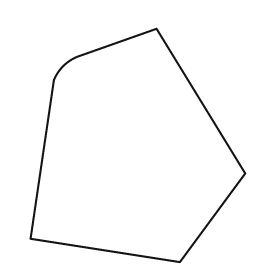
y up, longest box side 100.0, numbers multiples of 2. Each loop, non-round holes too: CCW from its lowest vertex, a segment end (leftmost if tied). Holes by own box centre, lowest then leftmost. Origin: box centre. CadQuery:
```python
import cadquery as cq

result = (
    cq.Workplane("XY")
    .moveTo(18.0, -50.0)
    .lineTo(46.0, -12.0)
    .lineTo(8.0, 50.0)
    .lineTo(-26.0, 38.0)
    .threePointArc((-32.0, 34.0), (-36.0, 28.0))
    .lineTo(-46.0, -40.0)
    .close()
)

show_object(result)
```